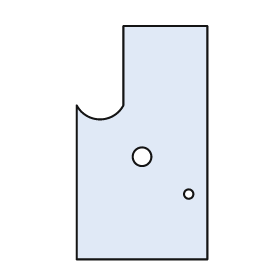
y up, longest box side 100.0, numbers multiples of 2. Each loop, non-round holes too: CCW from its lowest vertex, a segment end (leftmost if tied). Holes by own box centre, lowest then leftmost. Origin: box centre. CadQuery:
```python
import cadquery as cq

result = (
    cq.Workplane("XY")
    .moveTo(-28.0, -50.0)
    .lineTo(28.0, -50.0)
    .lineTo(28.0, 50.0)
    .lineTo(-8.0, 50.0)
    .lineTo(-8.0, 16.0)
    .threePointArc((-18.0, 10.0), (-28.0, 16.0))
    .close()
    .moveTo(20.0, -22.0)
    .circle(2.0)
    .moveTo(0.0, -6.0)
    .circle(4.0)
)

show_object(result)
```